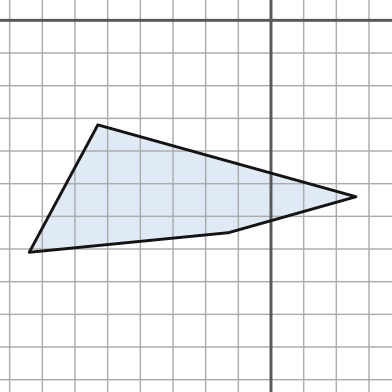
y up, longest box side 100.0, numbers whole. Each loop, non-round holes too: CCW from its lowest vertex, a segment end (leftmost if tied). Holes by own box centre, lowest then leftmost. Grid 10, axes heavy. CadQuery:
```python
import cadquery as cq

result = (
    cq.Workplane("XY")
    .moveTo(-74.0, -71.0)
    .lineTo(-13.0, -65.0)
    .lineTo(26.0, -54.0)
    .lineTo(-53.0, -32.0)
    .close()
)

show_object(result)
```